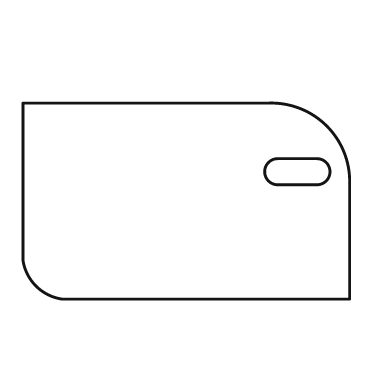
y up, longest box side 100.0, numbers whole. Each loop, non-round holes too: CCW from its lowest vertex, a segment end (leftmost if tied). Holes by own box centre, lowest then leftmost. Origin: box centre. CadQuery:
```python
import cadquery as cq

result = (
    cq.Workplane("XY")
    .moveTo(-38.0, -30.0)
    .lineTo(50.0, -30.0)
    .lineTo(50.0, 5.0)
    .threePointArc((43.0, 23.0), (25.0, 30.0))
    .lineTo(-50.0, 30.0)
    .lineTo(-50.0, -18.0)
    .threePointArc((-46.0, -26.0), (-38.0, -30.0))
    .close()
    .moveTo(28.0, 5.0)
    .lineTo(40.0, 5.0)
    .threePointArc((44.0, 9.0), (40.0, 13.0))
    .lineTo(28.0, 13.0)
    .threePointArc((24.0, 9.0), (28.0, 5.0))
    .close()
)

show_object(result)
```